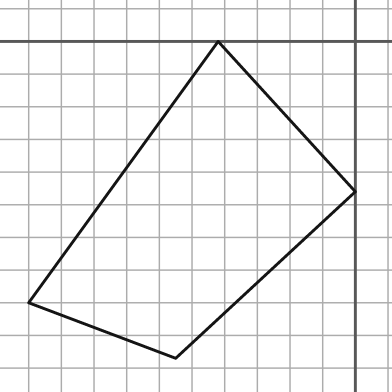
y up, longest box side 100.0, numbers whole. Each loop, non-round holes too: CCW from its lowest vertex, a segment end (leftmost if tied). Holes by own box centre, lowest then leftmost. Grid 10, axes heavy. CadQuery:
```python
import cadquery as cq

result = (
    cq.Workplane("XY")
    .moveTo(-55.0, -97.0)
    .lineTo(0.0, -46.0)
    .lineTo(-42.0, 0.0)
    .lineTo(-100.0, -80.0)
    .close()
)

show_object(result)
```